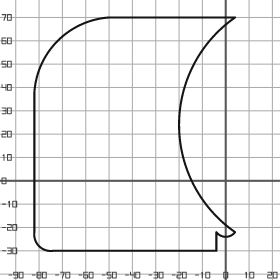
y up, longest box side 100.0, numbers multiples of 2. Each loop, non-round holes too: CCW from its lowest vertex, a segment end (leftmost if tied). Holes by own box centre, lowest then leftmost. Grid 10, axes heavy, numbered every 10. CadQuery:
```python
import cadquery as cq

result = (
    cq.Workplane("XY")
    .moveTo(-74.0, -30.0)
    .lineTo(-4.0, -30.0)
    .lineTo(-4.0, -22.0)
    .threePointArc((0.0, -24.0), (4.0, -22.0))
    .threePointArc((-20.0, 24.0), (4.0, 70.0))
    .lineTo(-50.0, 70.0)
    .threePointArc((-72.0, 60.0), (-82.0, 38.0))
    .lineTo(-82.0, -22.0)
    .threePointArc((-80.0, -28.0), (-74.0, -30.0))
    .close()
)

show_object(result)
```